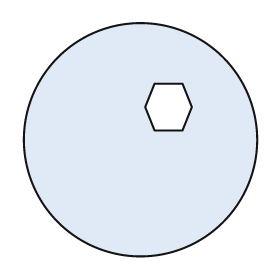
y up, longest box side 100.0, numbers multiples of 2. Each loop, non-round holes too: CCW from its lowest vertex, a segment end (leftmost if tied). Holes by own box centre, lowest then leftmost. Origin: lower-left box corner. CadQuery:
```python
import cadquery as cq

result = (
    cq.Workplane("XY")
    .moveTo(50.0, 50.0)
    .circle(50.0)
    .moveTo(56.0, 54.0)
    .lineTo(68.0, 54.0)
    .lineTo(72.0, 64.0)
    .lineTo(68.0, 74.0)
    .lineTo(56.0, 74.0)
    .lineTo(52.0, 64.0)
    .close()
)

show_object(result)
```